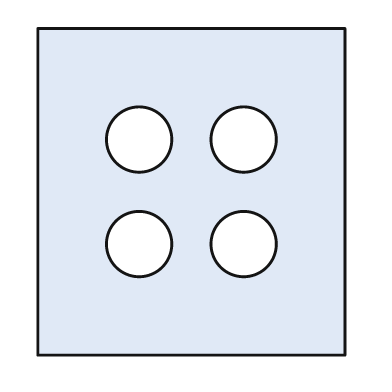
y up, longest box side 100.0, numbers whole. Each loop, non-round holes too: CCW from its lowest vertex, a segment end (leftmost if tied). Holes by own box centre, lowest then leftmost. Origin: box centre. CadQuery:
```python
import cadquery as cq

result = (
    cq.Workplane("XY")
    .moveTo(-47.0, -50.0)
    .lineTo(47.0, -50.0)
    .lineTo(47.0, 50.0)
    .lineTo(-47.0, 50.0)
    .close()
    .moveTo(-16.0, -16.0)
    .circle(10.0)
    .moveTo(16.0, -16.0)
    .circle(10.0)
    .moveTo(-16.0, 16.0)
    .circle(10.0)
    .moveTo(16.0, 16.0)
    .circle(10.0)
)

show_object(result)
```